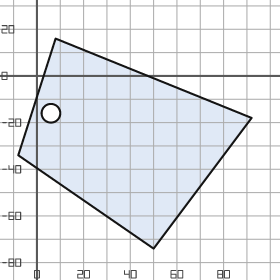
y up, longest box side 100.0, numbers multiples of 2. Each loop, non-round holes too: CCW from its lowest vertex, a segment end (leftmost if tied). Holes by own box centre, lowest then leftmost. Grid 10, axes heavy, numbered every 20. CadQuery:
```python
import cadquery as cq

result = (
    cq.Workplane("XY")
    .moveTo(50.0, -74.0)
    .lineTo(92.0, -18.0)
    .lineTo(8.0, 16.0)
    .lineTo(-8.0, -34.0)
    .close()
    .moveTo(6.0, -16.0)
    .circle(4.0)
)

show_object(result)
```